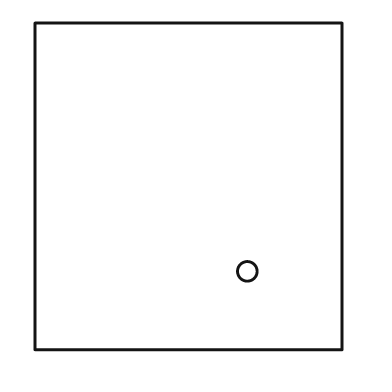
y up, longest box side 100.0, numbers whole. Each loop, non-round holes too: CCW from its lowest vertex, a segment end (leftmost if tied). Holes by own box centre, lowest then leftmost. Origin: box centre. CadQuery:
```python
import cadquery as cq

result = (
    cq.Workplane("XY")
    .moveTo(-47.0, -50.0)
    .lineTo(47.0, -50.0)
    .lineTo(47.0, 50.0)
    .lineTo(-47.0, 50.0)
    .close()
    .moveTo(18.0, -26.0)
    .circle(3.0)
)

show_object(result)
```